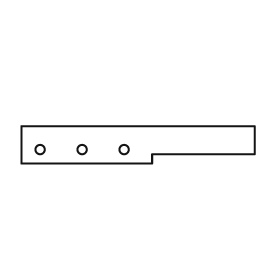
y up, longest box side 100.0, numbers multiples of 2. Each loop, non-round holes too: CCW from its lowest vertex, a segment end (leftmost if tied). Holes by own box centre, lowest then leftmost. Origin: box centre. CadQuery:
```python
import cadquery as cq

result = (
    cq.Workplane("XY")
    .moveTo(-50.0, -8.0)
    .lineTo(6.0, -8.0)
    .lineTo(6.0, -4.0)
    .lineTo(50.0, -4.0)
    .lineTo(50.0, 8.0)
    .lineTo(-50.0, 8.0)
    .close()
    .moveTo(-42.0, -2.0)
    .circle(2.0)
    .moveTo(-24.0, -2.0)
    .circle(2.0)
    .moveTo(-6.0, -2.0)
    .circle(2.0)
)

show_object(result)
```